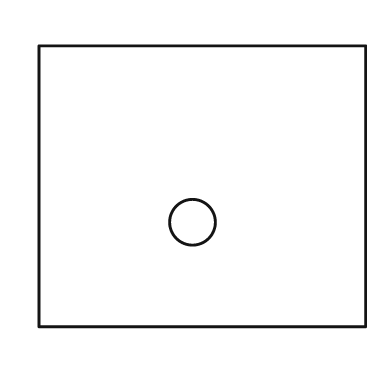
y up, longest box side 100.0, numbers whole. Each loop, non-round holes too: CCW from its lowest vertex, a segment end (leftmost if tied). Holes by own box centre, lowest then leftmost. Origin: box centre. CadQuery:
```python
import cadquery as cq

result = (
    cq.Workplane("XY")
    .moveTo(-50.0, -43.0)
    .lineTo(50.0, -43.0)
    .lineTo(50.0, 43.0)
    .lineTo(-50.0, 43.0)
    .close()
    .moveTo(-3.0, -11.0)
    .circle(7.0)
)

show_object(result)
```